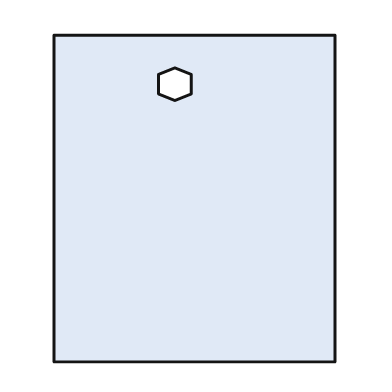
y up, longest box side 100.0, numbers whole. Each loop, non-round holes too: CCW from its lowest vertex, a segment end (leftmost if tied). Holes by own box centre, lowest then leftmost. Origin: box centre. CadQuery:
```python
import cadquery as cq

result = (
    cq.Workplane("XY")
    .moveTo(-43.0, -50.0)
    .lineTo(43.0, -50.0)
    .lineTo(43.0, 50.0)
    .lineTo(-43.0, 50.0)
    .close()
    .moveTo(-6.0, 30.0)
    .lineTo(-1.0, 32.0)
    .lineTo(-1.0, 38.0)
    .lineTo(-6.0, 40.0)
    .lineTo(-11.0, 38.0)
    .lineTo(-11.0, 32.0)
    .close()
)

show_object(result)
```